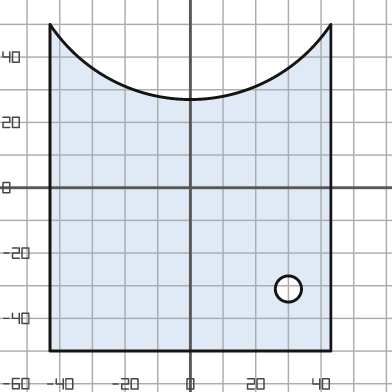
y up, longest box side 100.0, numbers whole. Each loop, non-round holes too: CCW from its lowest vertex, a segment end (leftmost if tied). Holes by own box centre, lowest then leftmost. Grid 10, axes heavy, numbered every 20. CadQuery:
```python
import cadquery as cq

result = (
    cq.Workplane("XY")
    .moveTo(-43.0, -50.0)
    .lineTo(43.0, -50.0)
    .lineTo(43.0, 50.0)
    .threePointArc((0.0, 27.0), (-43.0, 50.0))
    .close()
    .moveTo(30.0, -31.0)
    .circle(4.0)
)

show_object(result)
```